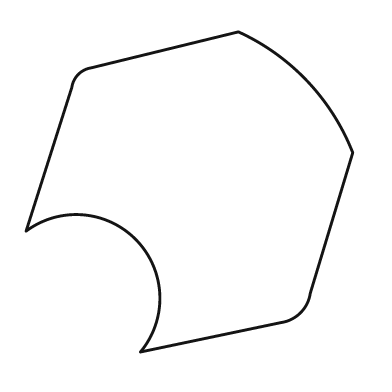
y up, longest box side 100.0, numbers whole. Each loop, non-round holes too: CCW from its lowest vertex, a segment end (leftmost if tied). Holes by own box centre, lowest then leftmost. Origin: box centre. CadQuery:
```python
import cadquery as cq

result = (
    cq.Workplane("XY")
    .moveTo(-15.0, -49.0)
    .lineTo(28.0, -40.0)
    .threePointArc((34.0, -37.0), (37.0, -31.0))
    .lineTo(50.0, 12.0)
    .threePointArc((36.0, 34.0), (15.0, 49.0))
    .lineTo(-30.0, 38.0)
    .threePointArc((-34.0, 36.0), (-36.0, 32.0))
    .lineTo(-50.0, -12.0)
    .threePointArc((-16.0, -15.0), (-15.0, -49.0))
    .close()
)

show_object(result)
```